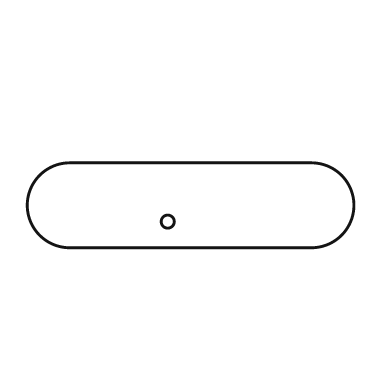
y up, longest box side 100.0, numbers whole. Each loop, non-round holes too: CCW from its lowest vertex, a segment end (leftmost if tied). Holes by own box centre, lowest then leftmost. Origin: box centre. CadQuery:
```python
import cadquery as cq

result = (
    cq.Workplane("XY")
    .moveTo(-37.0, -13.0)
    .lineTo(37.0, -13.0)
    .threePointArc((50.0, 0.0), (37.0, 13.0))
    .lineTo(-37.0, 13.0)
    .threePointArc((-50.0, 0.0), (-37.0, -13.0))
    .close()
    .moveTo(-7.0, -5.0)
    .circle(2.0)
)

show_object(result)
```